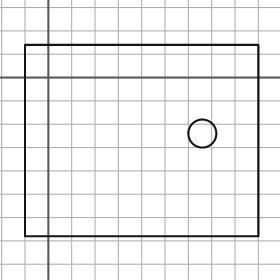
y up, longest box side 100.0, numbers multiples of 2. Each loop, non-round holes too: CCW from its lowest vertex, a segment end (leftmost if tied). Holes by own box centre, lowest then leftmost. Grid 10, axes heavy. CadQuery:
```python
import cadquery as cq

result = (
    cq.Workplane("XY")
    .moveTo(-10.0, -68.0)
    .lineTo(90.0, -68.0)
    .lineTo(90.0, 14.0)
    .lineTo(-10.0, 14.0)
    .close()
    .moveTo(66.0, -24.0)
    .circle(6.0)
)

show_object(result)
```